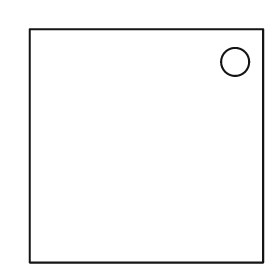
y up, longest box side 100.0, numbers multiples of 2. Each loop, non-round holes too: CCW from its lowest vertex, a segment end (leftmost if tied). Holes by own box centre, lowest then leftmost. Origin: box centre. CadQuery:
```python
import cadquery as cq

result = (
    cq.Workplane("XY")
    .moveTo(-50.0, -50.0)
    .lineTo(50.0, -50.0)
    .lineTo(50.0, 50.0)
    .lineTo(-50.0, 50.0)
    .close()
    .moveTo(38.0, 36.0)
    .circle(6.0)
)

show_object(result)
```